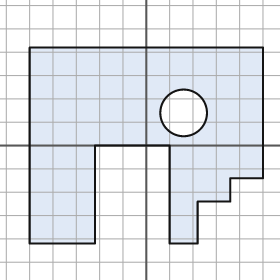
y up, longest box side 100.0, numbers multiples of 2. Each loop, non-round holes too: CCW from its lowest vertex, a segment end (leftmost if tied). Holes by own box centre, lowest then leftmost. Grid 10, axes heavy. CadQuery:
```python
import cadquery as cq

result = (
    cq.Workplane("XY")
    .moveTo(-50.0, -42.0)
    .lineTo(-22.0, -42.0)
    .lineTo(-22.0, 0.0)
    .lineTo(10.0, 0.0)
    .lineTo(10.0, -42.0)
    .lineTo(22.0, -42.0)
    .lineTo(22.0, -24.0)
    .lineTo(36.0, -24.0)
    .lineTo(36.0, -14.0)
    .lineTo(50.0, -14.0)
    .lineTo(50.0, 42.0)
    .lineTo(-50.0, 42.0)
    .close()
    .moveTo(16.0, 14.0)
    .circle(10.0)
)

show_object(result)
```